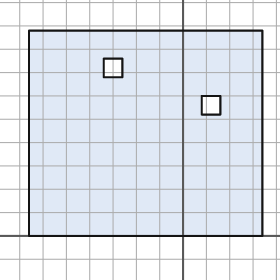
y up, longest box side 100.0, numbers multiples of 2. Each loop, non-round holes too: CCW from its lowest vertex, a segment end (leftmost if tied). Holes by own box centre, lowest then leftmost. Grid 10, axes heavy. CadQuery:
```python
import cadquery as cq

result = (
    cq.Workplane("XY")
    .moveTo(-66.0, 0.0)
    .lineTo(34.0, 0.0)
    .lineTo(34.0, 88.0)
    .lineTo(-66.0, 88.0)
    .close()
    .moveTo(8.0, 52.0)
    .lineTo(16.0, 52.0)
    .lineTo(16.0, 60.0)
    .lineTo(8.0, 60.0)
    .close()
    .moveTo(-34.0, 68.0)
    .lineTo(-26.0, 68.0)
    .lineTo(-26.0, 76.0)
    .lineTo(-34.0, 76.0)
    .close()
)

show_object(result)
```